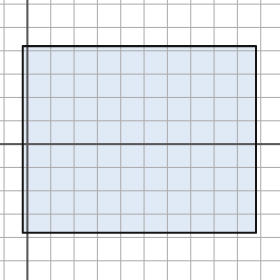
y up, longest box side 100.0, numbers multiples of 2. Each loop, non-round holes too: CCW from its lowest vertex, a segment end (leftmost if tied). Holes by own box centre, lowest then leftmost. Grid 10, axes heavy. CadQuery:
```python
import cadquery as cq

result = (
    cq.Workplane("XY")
    .moveTo(-2.0, -38.0)
    .lineTo(98.0, -38.0)
    .lineTo(98.0, 42.0)
    .lineTo(-2.0, 42.0)
    .close()
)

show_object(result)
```